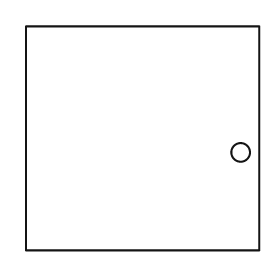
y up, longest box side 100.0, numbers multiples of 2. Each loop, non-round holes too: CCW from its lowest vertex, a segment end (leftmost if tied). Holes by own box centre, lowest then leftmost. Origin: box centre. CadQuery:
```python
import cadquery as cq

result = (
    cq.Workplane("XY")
    .moveTo(-50.0, -48.0)
    .lineTo(50.0, -48.0)
    .lineTo(50.0, 48.0)
    .lineTo(-50.0, 48.0)
    .close()
    .moveTo(42.0, -6.0)
    .circle(4.0)
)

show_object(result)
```